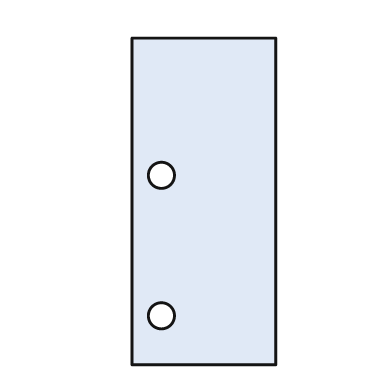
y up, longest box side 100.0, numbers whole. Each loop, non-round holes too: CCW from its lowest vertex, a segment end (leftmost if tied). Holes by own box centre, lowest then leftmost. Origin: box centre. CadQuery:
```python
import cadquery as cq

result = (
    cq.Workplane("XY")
    .moveTo(-22.0, -50.0)
    .lineTo(22.0, -50.0)
    .lineTo(22.0, 50.0)
    .lineTo(-22.0, 50.0)
    .close()
    .moveTo(-13.0, -35.0)
    .circle(4.0)
    .moveTo(-13.0, 8.0)
    .circle(4.0)
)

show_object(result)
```